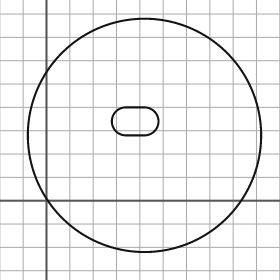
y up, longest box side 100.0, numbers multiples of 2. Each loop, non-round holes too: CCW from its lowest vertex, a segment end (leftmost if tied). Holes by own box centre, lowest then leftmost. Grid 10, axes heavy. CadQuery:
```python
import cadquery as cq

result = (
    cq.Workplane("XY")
    .moveTo(42.0, 28.0)
    .circle(50.0)
    .moveTo(34.0, 28.0)
    .lineTo(42.0, 28.0)
    .threePointArc((48.0, 34.0), (42.0, 40.0))
    .lineTo(34.0, 40.0)
    .threePointArc((28.0, 34.0), (34.0, 28.0))
    .close()
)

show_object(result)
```